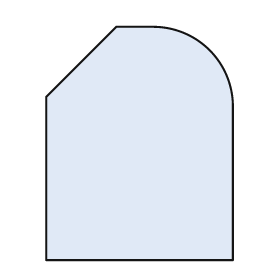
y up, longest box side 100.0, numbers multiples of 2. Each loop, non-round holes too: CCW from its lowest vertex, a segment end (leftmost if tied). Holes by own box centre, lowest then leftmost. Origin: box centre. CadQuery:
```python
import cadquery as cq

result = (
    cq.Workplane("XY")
    .moveTo(-40.0, -50.0)
    .lineTo(40.0, -50.0)
    .lineTo(40.0, 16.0)
    .threePointArc((30.0, 40.0), (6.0, 50.0))
    .lineTo(-10.0, 50.0)
    .lineTo(-40.0, 20.0)
    .close()
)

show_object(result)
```